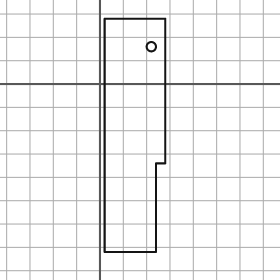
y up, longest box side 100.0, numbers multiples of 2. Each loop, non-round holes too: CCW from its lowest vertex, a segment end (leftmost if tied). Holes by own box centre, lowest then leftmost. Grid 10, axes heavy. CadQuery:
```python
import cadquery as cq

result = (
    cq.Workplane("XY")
    .moveTo(2.0, -72.0)
    .lineTo(24.0, -72.0)
    .lineTo(24.0, -34.0)
    .lineTo(28.0, -34.0)
    .lineTo(28.0, 28.0)
    .lineTo(2.0, 28.0)
    .close()
    .moveTo(22.0, 16.0)
    .circle(2.0)
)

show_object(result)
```